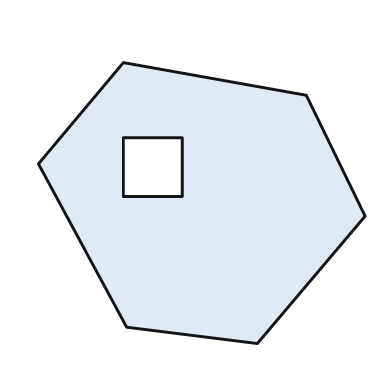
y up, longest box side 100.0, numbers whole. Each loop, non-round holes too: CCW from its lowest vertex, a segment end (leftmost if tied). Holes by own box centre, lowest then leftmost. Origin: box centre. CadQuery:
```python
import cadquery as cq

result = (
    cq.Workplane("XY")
    .moveTo(17.0, -43.0)
    .lineTo(50.0, -4.0)
    .lineTo(32.0, 33.0)
    .lineTo(-24.0, 43.0)
    .lineTo(-50.0, 12.0)
    .lineTo(-23.0, -38.0)
    .close()
    .moveTo(-24.0, 2.0)
    .lineTo(-6.0, 2.0)
    .lineTo(-6.0, 20.0)
    .lineTo(-24.0, 20.0)
    .close()
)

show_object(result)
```